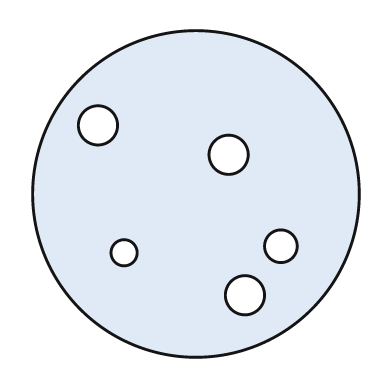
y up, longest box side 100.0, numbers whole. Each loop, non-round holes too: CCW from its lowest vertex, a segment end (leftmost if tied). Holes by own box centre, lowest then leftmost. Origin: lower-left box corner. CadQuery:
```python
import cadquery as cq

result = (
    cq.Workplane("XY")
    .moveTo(50.0, 50.0)
    .circle(50.0)
    .moveTo(65.0, 19.0)
    .circle(6.0)
    .moveTo(28.0, 32.0)
    .circle(4.0)
    .moveTo(76.0, 34.0)
    .circle(5.0)
    .moveTo(60.0, 62.0)
    .circle(6.0)
    .moveTo(20.0, 71.0)
    .circle(6.0)
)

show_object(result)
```